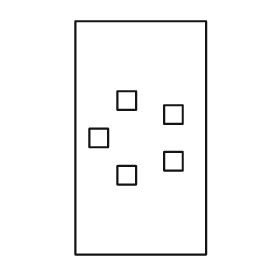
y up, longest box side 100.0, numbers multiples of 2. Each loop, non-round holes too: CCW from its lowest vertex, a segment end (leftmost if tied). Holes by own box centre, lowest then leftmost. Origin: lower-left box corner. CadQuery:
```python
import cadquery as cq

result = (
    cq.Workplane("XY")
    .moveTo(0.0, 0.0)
    .lineTo(56.0, 0.0)
    .lineTo(56.0, 100.0)
    .lineTo(0.0, 100.0)
    .close()
    .moveTo(18.0, 30.0)
    .lineTo(26.0, 30.0)
    .lineTo(26.0, 38.0)
    .lineTo(18.0, 38.0)
    .close()
    .moveTo(38.0, 36.0)
    .lineTo(46.0, 36.0)
    .lineTo(46.0, 44.0)
    .lineTo(38.0, 44.0)
    .close()
    .moveTo(6.0, 46.0)
    .lineTo(14.0, 46.0)
    .lineTo(14.0, 54.0)
    .lineTo(6.0, 54.0)
    .close()
    .moveTo(38.0, 56.0)
    .lineTo(46.0, 56.0)
    .lineTo(46.0, 64.0)
    .lineTo(38.0, 64.0)
    .close()
    .moveTo(18.0, 62.0)
    .lineTo(26.0, 62.0)
    .lineTo(26.0, 70.0)
    .lineTo(18.0, 70.0)
    .close()
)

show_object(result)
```